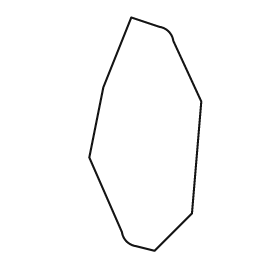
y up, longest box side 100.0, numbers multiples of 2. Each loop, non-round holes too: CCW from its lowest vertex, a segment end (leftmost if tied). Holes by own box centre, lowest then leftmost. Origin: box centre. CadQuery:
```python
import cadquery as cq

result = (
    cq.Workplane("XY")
    .moveTo(4.0, -50.0)
    .lineTo(20.0, -34.0)
    .lineTo(24.0, 14.0)
    .lineTo(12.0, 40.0)
    .threePointArc((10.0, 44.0), (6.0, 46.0))
    .lineTo(-6.0, 50.0)
    .lineTo(-18.0, 20.0)
    .lineTo(-24.0, -10.0)
    .lineTo(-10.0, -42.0)
    .threePointArc((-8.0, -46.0), (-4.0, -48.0))
    .close()
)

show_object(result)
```